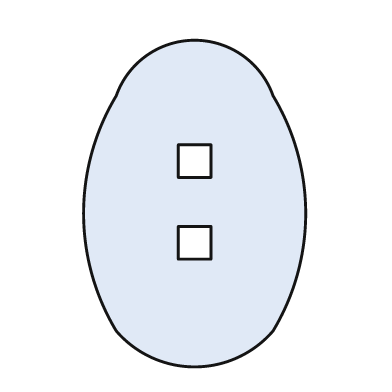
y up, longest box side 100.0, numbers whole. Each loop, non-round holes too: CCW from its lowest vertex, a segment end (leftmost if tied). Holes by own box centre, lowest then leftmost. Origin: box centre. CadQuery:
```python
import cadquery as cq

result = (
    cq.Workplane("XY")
    .moveTo(-24.0, -39.0)
    .threePointArc((0.0, -50.0), (24.0, -39.0))
    .threePointArc((34.0, -3.0), (24.0, 33.0))
    .threePointArc((0.0, 50.0), (-24.0, 33.0))
    .threePointArc((-34.0, -3.0), (-24.0, -39.0))
    .close()
    .moveTo(-5.0, -17.0)
    .lineTo(5.0, -17.0)
    .lineTo(5.0, -7.0)
    .lineTo(-5.0, -7.0)
    .close()
    .moveTo(-5.0, 8.0)
    .lineTo(5.0, 8.0)
    .lineTo(5.0, 18.0)
    .lineTo(-5.0, 18.0)
    .close()
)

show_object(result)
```